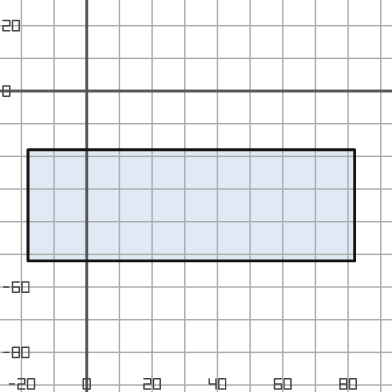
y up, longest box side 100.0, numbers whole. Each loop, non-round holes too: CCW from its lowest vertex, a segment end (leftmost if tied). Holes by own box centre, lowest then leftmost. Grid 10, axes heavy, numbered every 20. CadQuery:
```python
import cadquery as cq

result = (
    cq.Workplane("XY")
    .moveTo(-18.0, -52.0)
    .lineTo(82.0, -52.0)
    .lineTo(82.0, -18.0)
    .lineTo(-18.0, -18.0)
    .close()
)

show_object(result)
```